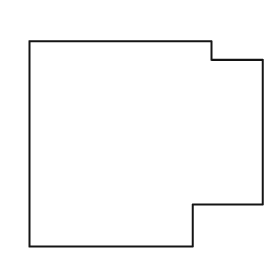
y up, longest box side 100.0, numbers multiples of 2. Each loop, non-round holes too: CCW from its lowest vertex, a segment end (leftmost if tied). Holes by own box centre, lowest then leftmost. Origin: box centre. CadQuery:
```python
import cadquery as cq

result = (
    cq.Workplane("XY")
    .moveTo(-50.0, -44.0)
    .lineTo(20.0, -44.0)
    .lineTo(20.0, -26.0)
    .lineTo(50.0, -26.0)
    .lineTo(50.0, 36.0)
    .lineTo(28.0, 36.0)
    .lineTo(28.0, 44.0)
    .lineTo(-50.0, 44.0)
    .close()
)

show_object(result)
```